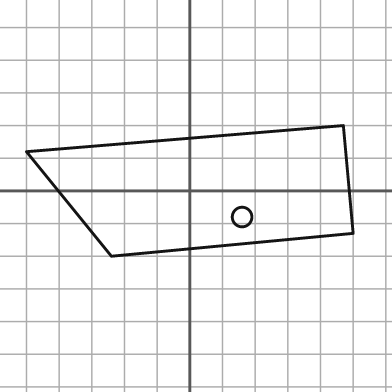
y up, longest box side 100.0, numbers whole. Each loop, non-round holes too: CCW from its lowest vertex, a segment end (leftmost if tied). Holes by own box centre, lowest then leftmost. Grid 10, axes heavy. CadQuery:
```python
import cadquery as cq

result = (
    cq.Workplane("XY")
    .moveTo(-24.0, -20.0)
    .lineTo(50.0, -13.0)
    .lineTo(47.0, 20.0)
    .lineTo(-50.0, 12.0)
    .close()
    .moveTo(16.0, -8.0)
    .circle(3.0)
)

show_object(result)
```